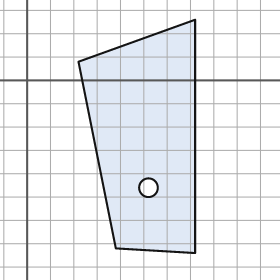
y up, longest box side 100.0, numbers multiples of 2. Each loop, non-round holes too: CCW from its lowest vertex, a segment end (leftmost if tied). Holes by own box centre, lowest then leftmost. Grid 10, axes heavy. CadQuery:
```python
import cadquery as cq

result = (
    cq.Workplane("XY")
    .moveTo(72.0, -74.0)
    .lineTo(72.0, 26.0)
    .lineTo(22.0, 8.0)
    .lineTo(38.0, -72.0)
    .close()
    .moveTo(52.0, -46.0)
    .circle(4.0)
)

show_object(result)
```